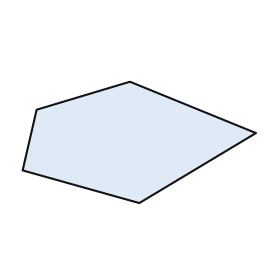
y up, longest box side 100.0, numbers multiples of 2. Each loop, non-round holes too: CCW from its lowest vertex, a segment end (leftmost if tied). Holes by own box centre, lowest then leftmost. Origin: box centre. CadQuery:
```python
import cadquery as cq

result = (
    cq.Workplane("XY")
    .moveTo(0.0, -26.0)
    .lineTo(50.0, 4.0)
    .lineTo(-4.0, 26.0)
    .lineTo(-44.0, 14.0)
    .lineTo(-50.0, -12.0)
    .close()
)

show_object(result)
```